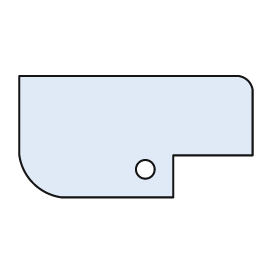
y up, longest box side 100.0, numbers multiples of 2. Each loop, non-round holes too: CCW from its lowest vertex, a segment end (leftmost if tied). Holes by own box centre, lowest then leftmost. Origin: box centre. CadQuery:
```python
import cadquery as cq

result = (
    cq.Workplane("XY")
    .moveTo(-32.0, -26.0)
    .lineTo(16.0, -26.0)
    .lineTo(16.0, -8.0)
    .lineTo(50.0, -8.0)
    .lineTo(50.0, 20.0)
    .threePointArc((48.0, 24.0), (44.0, 26.0))
    .lineTo(-50.0, 26.0)
    .lineTo(-50.0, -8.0)
    .threePointArc((-44.0, -20.0), (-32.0, -26.0))
    .close()
    .moveTo(4.0, -14.0)
    .circle(4.0)
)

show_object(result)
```